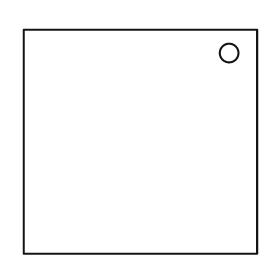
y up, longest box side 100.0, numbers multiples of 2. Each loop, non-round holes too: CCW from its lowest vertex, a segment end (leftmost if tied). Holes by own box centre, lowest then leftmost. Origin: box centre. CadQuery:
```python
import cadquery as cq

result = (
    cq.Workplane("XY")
    .moveTo(-50.0, -48.0)
    .lineTo(50.0, -48.0)
    .lineTo(50.0, 48.0)
    .lineTo(-50.0, 48.0)
    .close()
    .moveTo(38.0, 38.0)
    .circle(4.0)
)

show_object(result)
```